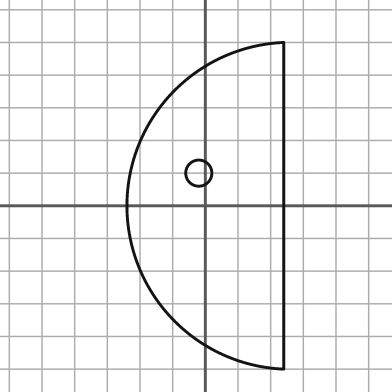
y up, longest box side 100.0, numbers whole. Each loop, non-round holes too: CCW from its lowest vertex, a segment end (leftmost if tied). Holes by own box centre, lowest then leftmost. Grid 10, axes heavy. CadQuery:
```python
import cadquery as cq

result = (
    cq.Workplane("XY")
    .moveTo(24.0, -50.0)
    .lineTo(24.0, 50.0)
    .threePointArc((-24.0, 0.0), (24.0, -50.0))
    .close()
    .moveTo(-2.0, 10.0)
    .circle(4.0)
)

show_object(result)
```